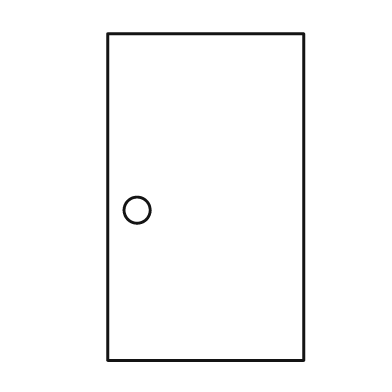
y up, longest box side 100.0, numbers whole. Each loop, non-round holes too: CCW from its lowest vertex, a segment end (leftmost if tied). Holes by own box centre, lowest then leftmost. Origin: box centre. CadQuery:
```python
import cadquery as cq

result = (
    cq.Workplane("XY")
    .moveTo(-30.0, -50.0)
    .lineTo(30.0, -50.0)
    .lineTo(30.0, 50.0)
    .lineTo(-30.0, 50.0)
    .close()
    .moveTo(-21.0, -4.0)
    .circle(4.0)
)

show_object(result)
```